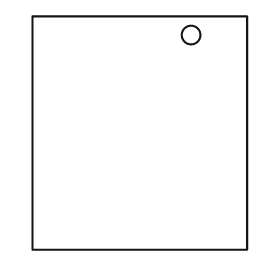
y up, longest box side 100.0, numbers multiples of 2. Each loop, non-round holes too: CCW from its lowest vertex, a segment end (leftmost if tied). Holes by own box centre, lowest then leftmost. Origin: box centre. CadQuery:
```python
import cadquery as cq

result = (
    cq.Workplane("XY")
    .moveTo(-46.0, -50.0)
    .lineTo(46.0, -50.0)
    .lineTo(46.0, 50.0)
    .lineTo(-46.0, 50.0)
    .close()
    .moveTo(22.0, 42.0)
    .circle(4.0)
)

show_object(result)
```